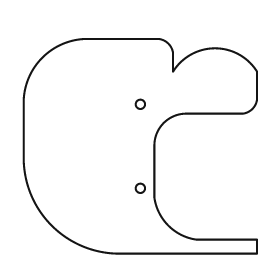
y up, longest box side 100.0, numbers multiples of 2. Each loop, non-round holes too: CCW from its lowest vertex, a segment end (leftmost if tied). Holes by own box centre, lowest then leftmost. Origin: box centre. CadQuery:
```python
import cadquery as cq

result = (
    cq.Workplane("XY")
    .moveTo(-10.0, -46.0)
    .lineTo(50.0, -46.0)
    .lineTo(50.0, -40.0)
    .lineTo(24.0, -40.0)
    .threePointArc((12.0, -34.0), (6.0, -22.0))
    .lineTo(6.0, 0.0)
    .threePointArc((10.0, 10.0), (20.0, 14.0))
    .lineTo(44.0, 14.0)
    .threePointArc((48.0, 16.0), (50.0, 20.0))
    .lineTo(50.0, 32.0)
    .threePointArc((32.0, 42.0), (14.0, 32.0))
    .lineTo(14.0, 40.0)
    .threePointArc((12.0, 44.0), (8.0, 46.0))
    .lineTo(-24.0, 46.0)
    .threePointArc((-42.0, 38.0), (-50.0, 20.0))
    .lineTo(-50.0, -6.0)
    .threePointArc((-38.0, -34.0), (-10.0, -46.0))
    .close()
    .moveTo(0.0, -18.0)
    .circle(2.0)
    .moveTo(0.0, 18.0)
    .circle(2.0)
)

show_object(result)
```